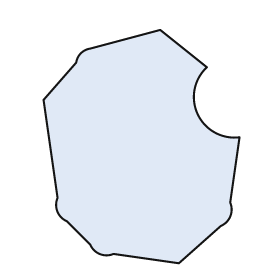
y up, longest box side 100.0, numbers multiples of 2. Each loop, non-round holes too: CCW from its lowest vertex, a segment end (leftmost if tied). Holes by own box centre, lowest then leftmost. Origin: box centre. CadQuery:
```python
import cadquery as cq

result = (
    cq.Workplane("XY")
    .moveTo(16.0, -50.0)
    .lineTo(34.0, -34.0)
    .threePointArc((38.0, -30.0), (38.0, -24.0))
    .lineTo(42.0, 4.0)
    .threePointArc((24.0, 14.0), (28.0, 34.0))
    .lineTo(8.0, 50.0)
    .lineTo(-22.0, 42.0)
    .threePointArc((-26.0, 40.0), (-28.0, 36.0))
    .lineTo(-42.0, 20.0)
    .lineTo(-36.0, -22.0)
    .threePointArc((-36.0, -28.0), (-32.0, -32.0))
    .lineTo(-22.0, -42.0)
    .threePointArc((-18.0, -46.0), (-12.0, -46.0))
    .close()
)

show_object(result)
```